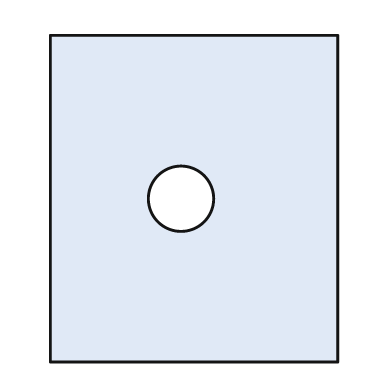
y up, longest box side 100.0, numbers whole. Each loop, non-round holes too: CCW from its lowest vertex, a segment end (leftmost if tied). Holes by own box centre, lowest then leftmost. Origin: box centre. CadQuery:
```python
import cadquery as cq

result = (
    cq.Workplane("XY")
    .moveTo(-44.0, -50.0)
    .lineTo(44.0, -50.0)
    .lineTo(44.0, 50.0)
    .lineTo(-44.0, 50.0)
    .close()
    .moveTo(-4.0, 0.0)
    .circle(10.0)
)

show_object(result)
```